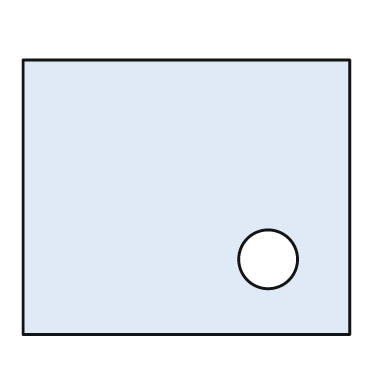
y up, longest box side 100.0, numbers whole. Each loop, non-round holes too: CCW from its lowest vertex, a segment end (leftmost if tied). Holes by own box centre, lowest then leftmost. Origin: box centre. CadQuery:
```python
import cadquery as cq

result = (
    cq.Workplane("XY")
    .moveTo(-50.0, -42.0)
    .lineTo(50.0, -42.0)
    .lineTo(50.0, 42.0)
    .lineTo(-50.0, 42.0)
    .close()
    .moveTo(25.0, -19.0)
    .circle(9.0)
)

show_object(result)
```